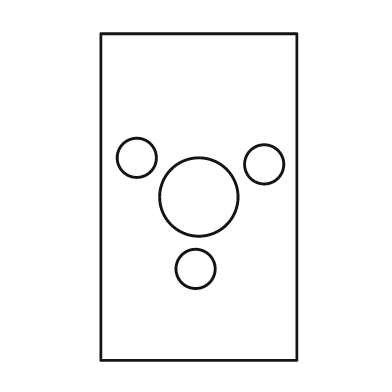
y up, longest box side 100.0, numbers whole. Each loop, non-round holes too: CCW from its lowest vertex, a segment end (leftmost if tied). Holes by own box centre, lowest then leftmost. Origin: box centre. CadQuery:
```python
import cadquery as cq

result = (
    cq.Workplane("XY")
    .moveTo(-30.0, -50.0)
    .lineTo(30.0, -50.0)
    .lineTo(30.0, 50.0)
    .lineTo(-30.0, 50.0)
    .close()
    .moveTo(-1.0, -22.0)
    .circle(6.0)
    .moveTo(0.0, 0.0)
    .circle(12.0)
    .moveTo(20.0, 10.0)
    .circle(6.0)
    .moveTo(-19.0, 12.0)
    .circle(6.0)
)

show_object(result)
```